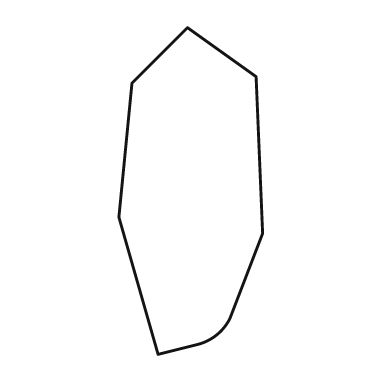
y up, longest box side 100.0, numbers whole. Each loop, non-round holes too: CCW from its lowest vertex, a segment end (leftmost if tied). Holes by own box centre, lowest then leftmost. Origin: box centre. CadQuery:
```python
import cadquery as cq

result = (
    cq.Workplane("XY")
    .moveTo(-10.0, -50.0)
    .lineTo(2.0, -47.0)
    .threePointArc((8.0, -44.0), (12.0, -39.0))
    .lineTo(22.0, -13.0)
    .lineTo(20.0, 35.0)
    .lineTo(-1.0, 50.0)
    .lineTo(-18.0, 33.0)
    .lineTo(-22.0, -8.0)
    .close()
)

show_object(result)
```